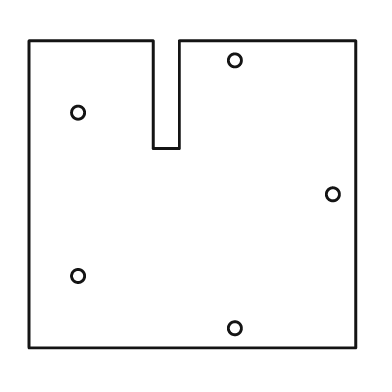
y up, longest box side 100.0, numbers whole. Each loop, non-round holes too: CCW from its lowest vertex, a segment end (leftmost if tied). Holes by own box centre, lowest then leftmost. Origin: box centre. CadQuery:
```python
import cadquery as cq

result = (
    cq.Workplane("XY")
    .moveTo(-50.0, -47.0)
    .lineTo(50.0, -47.0)
    .lineTo(50.0, 47.0)
    .lineTo(-4.0, 47.0)
    .lineTo(-4.0, 14.0)
    .lineTo(-12.0, 14.0)
    .lineTo(-12.0, 47.0)
    .lineTo(-50.0, 47.0)
    .close()
    .moveTo(13.0, -41.0)
    .circle(2.0)
    .moveTo(-35.0, -25.0)
    .circle(2.0)
    .moveTo(43.0, 0.0)
    .circle(2.0)
    .moveTo(-35.0, 25.0)
    .circle(2.0)
    .moveTo(13.0, 41.0)
    .circle(2.0)
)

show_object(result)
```